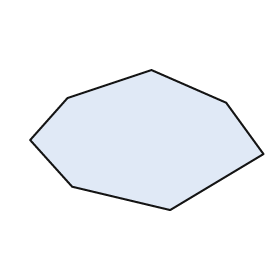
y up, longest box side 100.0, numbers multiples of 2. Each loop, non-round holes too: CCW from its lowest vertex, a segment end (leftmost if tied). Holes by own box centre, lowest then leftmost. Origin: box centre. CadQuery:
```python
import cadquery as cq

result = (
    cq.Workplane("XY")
    .moveTo(10.0, -30.0)
    .lineTo(50.0, -6.0)
    .lineTo(34.0, 16.0)
    .lineTo(2.0, 30.0)
    .lineTo(-34.0, 18.0)
    .lineTo(-50.0, 0.0)
    .lineTo(-32.0, -20.0)
    .close()
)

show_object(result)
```